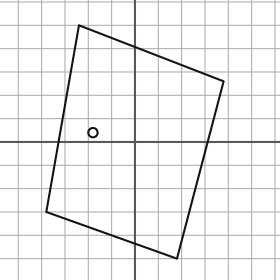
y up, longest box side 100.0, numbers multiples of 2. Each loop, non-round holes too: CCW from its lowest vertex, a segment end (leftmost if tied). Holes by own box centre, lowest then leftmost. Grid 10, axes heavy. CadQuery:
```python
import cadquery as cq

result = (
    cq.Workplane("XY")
    .moveTo(18.0, -50.0)
    .lineTo(38.0, 26.0)
    .lineTo(-24.0, 50.0)
    .lineTo(-38.0, -30.0)
    .close()
    .moveTo(-18.0, 4.0)
    .circle(2.0)
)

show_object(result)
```